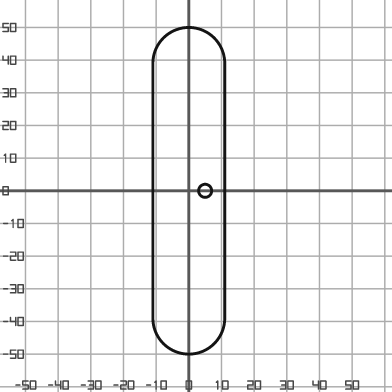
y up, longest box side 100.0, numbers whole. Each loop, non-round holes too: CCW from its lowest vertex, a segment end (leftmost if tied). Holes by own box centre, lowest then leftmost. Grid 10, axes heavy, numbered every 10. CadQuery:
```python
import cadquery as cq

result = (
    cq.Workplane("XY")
    .moveTo(-11.0, -39.0)
    .threePointArc((0.0, -50.0), (11.0, -39.0))
    .lineTo(11.0, 39.0)
    .threePointArc((0.0, 50.0), (-11.0, 39.0))
    .close()
    .moveTo(5.0, 0.0)
    .circle(2.0)
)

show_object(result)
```